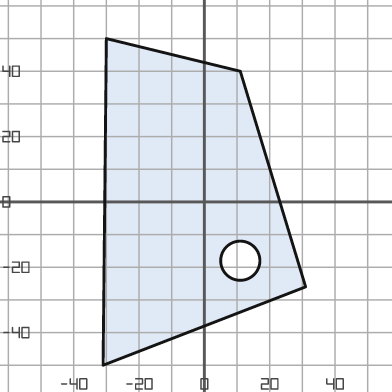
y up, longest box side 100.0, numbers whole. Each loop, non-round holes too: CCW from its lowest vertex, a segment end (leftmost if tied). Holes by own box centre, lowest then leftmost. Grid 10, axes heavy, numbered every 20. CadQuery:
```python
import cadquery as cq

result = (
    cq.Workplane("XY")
    .moveTo(-31.0, -50.0)
    .lineTo(31.0, -26.0)
    .lineTo(11.0, 40.0)
    .lineTo(-30.0, 50.0)
    .close()
    .moveTo(11.0, -18.0)
    .circle(6.0)
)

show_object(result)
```